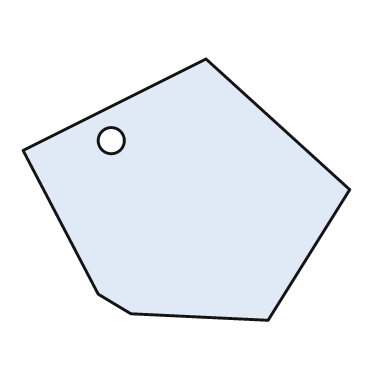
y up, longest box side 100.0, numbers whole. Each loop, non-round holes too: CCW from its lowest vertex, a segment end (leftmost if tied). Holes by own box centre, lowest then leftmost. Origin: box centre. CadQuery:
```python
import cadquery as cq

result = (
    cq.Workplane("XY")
    .moveTo(25.0, -40.0)
    .lineTo(50.0, 0.0)
    .lineTo(6.0, 40.0)
    .lineTo(-50.0, 12.0)
    .lineTo(-27.0, -32.0)
    .lineTo(-17.0, -38.0)
    .close()
    .moveTo(-23.0, 15.0)
    .circle(4.0)
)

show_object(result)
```